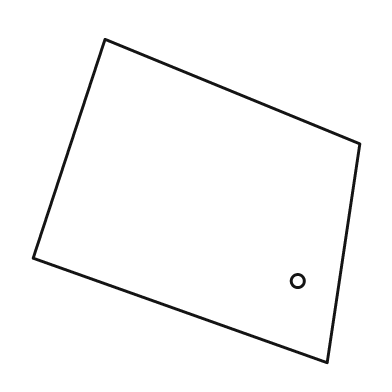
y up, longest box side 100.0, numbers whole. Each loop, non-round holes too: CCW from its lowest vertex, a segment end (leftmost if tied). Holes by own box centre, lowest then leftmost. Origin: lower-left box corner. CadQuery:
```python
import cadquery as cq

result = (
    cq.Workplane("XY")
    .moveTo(90.0, 0.0)
    .lineTo(100.0, 67.0)
    .lineTo(22.0, 99.0)
    .lineTo(0.0, 32.0)
    .close()
    .moveTo(81.0, 25.0)
    .circle(2.0)
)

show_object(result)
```